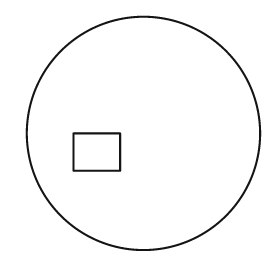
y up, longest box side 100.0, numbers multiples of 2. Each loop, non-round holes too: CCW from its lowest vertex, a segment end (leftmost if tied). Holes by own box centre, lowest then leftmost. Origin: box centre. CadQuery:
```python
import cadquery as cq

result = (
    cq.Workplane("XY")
    .moveTo(0.0, 0.0)
    .circle(50.0)
    .moveTo(-30.0, -16.0)
    .lineTo(-10.0, -16.0)
    .lineTo(-10.0, 0.0)
    .lineTo(-30.0, 0.0)
    .close()
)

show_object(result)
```